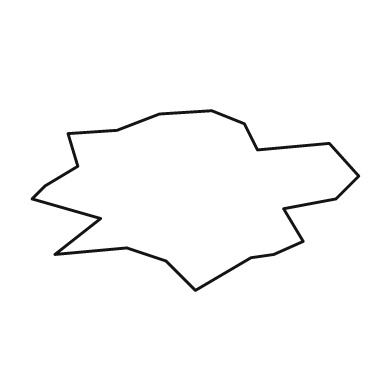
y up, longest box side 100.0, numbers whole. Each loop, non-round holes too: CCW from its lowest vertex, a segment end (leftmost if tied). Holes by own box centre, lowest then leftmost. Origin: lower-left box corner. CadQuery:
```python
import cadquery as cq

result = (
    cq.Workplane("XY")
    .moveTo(50.0, 0.0)
    .lineTo(67.0, 10.0)
    .lineTo(74.0, 11.0)
    .lineTo(83.0, 15.0)
    .lineTo(77.0, 25.0)
    .lineTo(93.0, 28.0)
    .lineTo(100.0, 35.0)
    .lineTo(91.0, 45.0)
    .lineTo(69.0, 43.0)
    .lineTo(65.0, 51.0)
    .lineTo(55.0, 55.0)
    .lineTo(39.0, 54.0)
    .lineTo(26.0, 49.0)
    .lineTo(11.0, 48.0)
    .lineTo(14.0, 38.0)
    .lineTo(4.0, 32.0)
    .lineTo(0.0, 28.0)
    .lineTo(21.0, 22.0)
    .lineTo(7.0, 11.0)
    .lineTo(29.0, 13.0)
    .lineTo(41.0, 9.0)
    .close()
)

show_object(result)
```